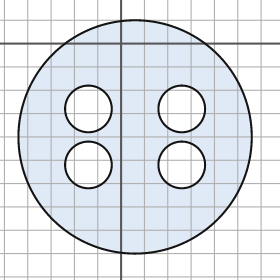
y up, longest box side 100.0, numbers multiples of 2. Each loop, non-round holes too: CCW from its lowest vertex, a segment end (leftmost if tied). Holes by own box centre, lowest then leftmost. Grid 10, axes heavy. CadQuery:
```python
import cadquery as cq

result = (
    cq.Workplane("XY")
    .moveTo(6.0, -40.0)
    .circle(50.0)
    .moveTo(-14.0, -52.0)
    .circle(10.0)
    .moveTo(26.0, -52.0)
    .circle(10.0)
    .moveTo(-14.0, -28.0)
    .circle(10.0)
    .moveTo(26.0, -28.0)
    .circle(10.0)
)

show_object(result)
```